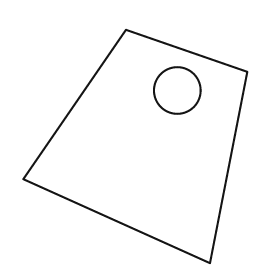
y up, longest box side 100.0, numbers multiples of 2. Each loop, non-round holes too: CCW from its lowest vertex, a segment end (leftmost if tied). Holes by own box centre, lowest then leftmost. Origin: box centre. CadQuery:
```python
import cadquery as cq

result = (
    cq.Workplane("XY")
    .moveTo(32.0, -50.0)
    .lineTo(48.0, 32.0)
    .lineTo(-4.0, 50.0)
    .lineTo(-48.0, -14.0)
    .close()
    .moveTo(18.0, 24.0)
    .circle(10.0)
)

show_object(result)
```